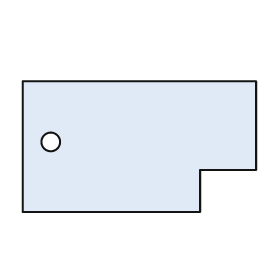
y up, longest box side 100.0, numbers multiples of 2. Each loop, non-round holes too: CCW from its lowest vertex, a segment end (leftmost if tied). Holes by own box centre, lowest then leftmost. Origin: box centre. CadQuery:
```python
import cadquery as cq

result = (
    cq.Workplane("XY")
    .moveTo(-50.0, -28.0)
    .lineTo(26.0, -28.0)
    .lineTo(26.0, -10.0)
    .lineTo(50.0, -10.0)
    .lineTo(50.0, 28.0)
    .lineTo(-50.0, 28.0)
    .close()
    .moveTo(-38.0, 2.0)
    .circle(4.0)
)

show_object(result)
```